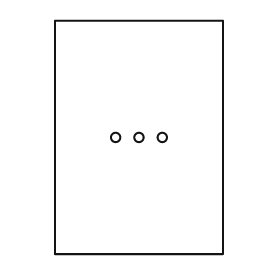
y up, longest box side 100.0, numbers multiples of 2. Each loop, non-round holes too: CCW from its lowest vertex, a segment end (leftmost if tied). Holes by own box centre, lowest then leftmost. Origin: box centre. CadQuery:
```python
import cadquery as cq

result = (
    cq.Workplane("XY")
    .moveTo(-36.0, -50.0)
    .lineTo(36.0, -50.0)
    .lineTo(36.0, 50.0)
    .lineTo(-36.0, 50.0)
    .close()
    .moveTo(-10.0, 0.0)
    .circle(2.0)
    .moveTo(0.0, 0.0)
    .circle(2.0)
    .moveTo(10.0, 0.0)
    .circle(2.0)
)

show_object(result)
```